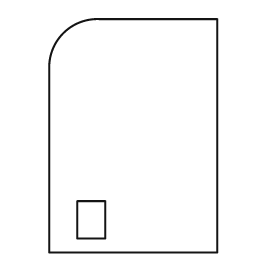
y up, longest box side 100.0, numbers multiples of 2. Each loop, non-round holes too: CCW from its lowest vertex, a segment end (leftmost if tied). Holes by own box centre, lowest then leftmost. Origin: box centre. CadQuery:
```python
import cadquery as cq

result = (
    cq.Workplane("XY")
    .moveTo(-36.0, -50.0)
    .lineTo(36.0, -50.0)
    .lineTo(36.0, 50.0)
    .lineTo(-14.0, 50.0)
    .threePointArc((-30.0, 44.0), (-36.0, 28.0))
    .close()
    .moveTo(-24.0, -44.0)
    .lineTo(-12.0, -44.0)
    .lineTo(-12.0, -28.0)
    .lineTo(-24.0, -28.0)
    .close()
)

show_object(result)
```